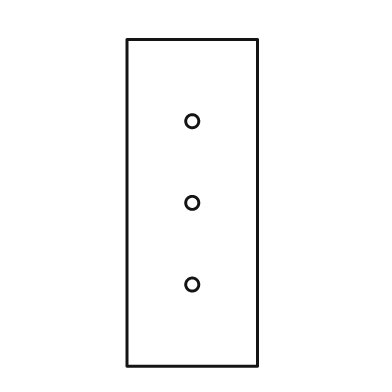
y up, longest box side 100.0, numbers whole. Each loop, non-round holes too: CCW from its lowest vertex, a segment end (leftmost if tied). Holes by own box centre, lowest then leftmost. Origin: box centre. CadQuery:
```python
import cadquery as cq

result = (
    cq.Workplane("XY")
    .moveTo(-20.0, -50.0)
    .lineTo(20.0, -50.0)
    .lineTo(20.0, 50.0)
    .lineTo(-20.0, 50.0)
    .close()
    .moveTo(0.0, -25.0)
    .circle(2.0)
    .moveTo(0.0, 0.0)
    .circle(2.0)
    .moveTo(0.0, 25.0)
    .circle(2.0)
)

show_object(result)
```